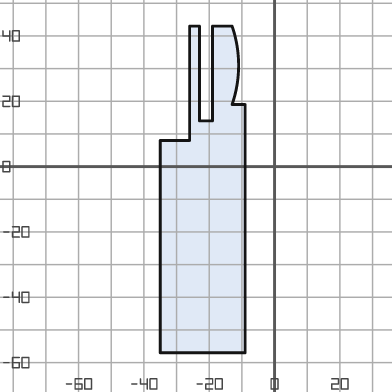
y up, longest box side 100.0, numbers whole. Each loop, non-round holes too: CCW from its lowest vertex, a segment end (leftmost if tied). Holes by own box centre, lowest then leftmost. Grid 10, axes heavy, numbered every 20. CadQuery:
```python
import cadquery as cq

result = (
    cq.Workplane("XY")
    .moveTo(-35.0, -57.0)
    .lineTo(-9.0, -57.0)
    .lineTo(-9.0, 19.0)
    .lineTo(-13.0, 19.0)
    .threePointArc((-11.0, 31.0), (-13.0, 43.0))
    .lineTo(-19.0, 43.0)
    .lineTo(-19.0, 14.0)
    .lineTo(-23.0, 14.0)
    .lineTo(-23.0, 43.0)
    .lineTo(-26.0, 43.0)
    .lineTo(-26.0, 8.0)
    .lineTo(-35.0, 8.0)
    .close()
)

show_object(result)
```